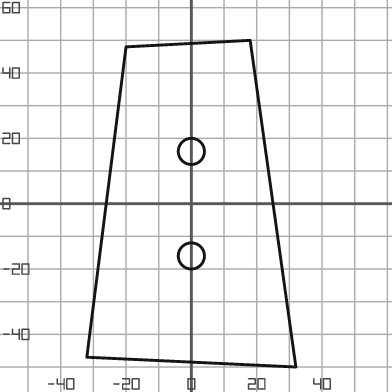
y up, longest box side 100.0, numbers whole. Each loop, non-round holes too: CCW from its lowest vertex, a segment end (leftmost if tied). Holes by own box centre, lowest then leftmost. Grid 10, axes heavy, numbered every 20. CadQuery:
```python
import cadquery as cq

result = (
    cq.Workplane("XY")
    .moveTo(32.0, -50.0)
    .lineTo(18.0, 50.0)
    .lineTo(-20.0, 48.0)
    .lineTo(-32.0, -47.0)
    .close()
    .moveTo(0.0, -16.0)
    .circle(4.0)
    .moveTo(0.0, 16.0)
    .circle(4.0)
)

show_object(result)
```